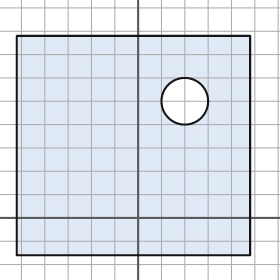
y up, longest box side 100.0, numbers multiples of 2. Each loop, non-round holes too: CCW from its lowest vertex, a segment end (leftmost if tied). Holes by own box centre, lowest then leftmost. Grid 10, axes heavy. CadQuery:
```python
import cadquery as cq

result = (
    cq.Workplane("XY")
    .moveTo(-52.0, -16.0)
    .lineTo(48.0, -16.0)
    .lineTo(48.0, 78.0)
    .lineTo(-52.0, 78.0)
    .close()
    .moveTo(20.0, 50.0)
    .circle(10.0)
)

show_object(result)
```